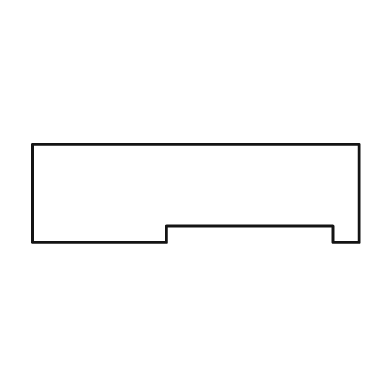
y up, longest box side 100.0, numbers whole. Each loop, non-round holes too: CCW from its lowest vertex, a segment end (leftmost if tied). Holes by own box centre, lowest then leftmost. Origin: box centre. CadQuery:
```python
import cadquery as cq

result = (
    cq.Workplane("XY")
    .moveTo(-50.0, -15.0)
    .lineTo(-9.0, -15.0)
    .lineTo(-9.0, -10.0)
    .lineTo(42.0, -10.0)
    .lineTo(42.0, -15.0)
    .lineTo(50.0, -15.0)
    .lineTo(50.0, 15.0)
    .lineTo(-50.0, 15.0)
    .close()
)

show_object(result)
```